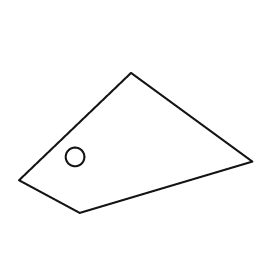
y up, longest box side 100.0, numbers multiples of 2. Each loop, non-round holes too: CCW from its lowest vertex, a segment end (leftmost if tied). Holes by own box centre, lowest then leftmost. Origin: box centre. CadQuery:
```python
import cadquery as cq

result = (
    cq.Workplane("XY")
    .moveTo(-24.0, -30.0)
    .lineTo(50.0, -8.0)
    .lineTo(-2.0, 30.0)
    .lineTo(-50.0, -16.0)
    .close()
    .moveTo(-26.0, -6.0)
    .circle(4.0)
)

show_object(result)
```